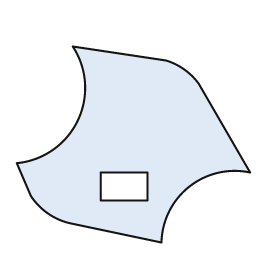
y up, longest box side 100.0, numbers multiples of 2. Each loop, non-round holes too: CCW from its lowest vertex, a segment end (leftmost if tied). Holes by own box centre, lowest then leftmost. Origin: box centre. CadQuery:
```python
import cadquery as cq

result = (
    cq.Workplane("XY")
    .moveTo(12.0, -42.0)
    .threePointArc((24.0, -18.0), (50.0, -12.0))
    .lineTo(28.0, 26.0)
    .threePointArc((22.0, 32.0), (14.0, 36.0))
    .lineTo(-26.0, 42.0)
    .threePointArc((-24.0, 10.0), (-50.0, -8.0))
    .lineTo(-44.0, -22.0)
    .threePointArc((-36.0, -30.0), (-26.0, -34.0))
    .close()
    .moveTo(-14.0, -24.0)
    .lineTo(6.0, -24.0)
    .lineTo(6.0, -12.0)
    .lineTo(-14.0, -12.0)
    .close()
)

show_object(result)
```